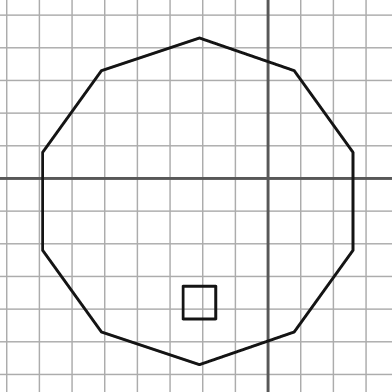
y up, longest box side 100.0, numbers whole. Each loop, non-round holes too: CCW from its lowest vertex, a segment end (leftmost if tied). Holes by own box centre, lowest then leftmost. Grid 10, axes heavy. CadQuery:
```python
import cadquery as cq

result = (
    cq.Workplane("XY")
    .moveTo(-21.0, -57.0)
    .lineTo(8.0, -47.0)
    .lineTo(26.0, -22.0)
    .lineTo(26.0, 8.0)
    .lineTo(8.0, 33.0)
    .lineTo(-21.0, 43.0)
    .lineTo(-51.0, 33.0)
    .lineTo(-69.0, 8.0)
    .lineTo(-69.0, -22.0)
    .lineTo(-51.0, -47.0)
    .close()
    .moveTo(-26.0, -43.0)
    .lineTo(-16.0, -43.0)
    .lineTo(-16.0, -33.0)
    .lineTo(-26.0, -33.0)
    .close()
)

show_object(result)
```